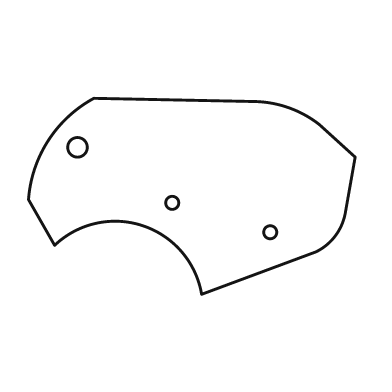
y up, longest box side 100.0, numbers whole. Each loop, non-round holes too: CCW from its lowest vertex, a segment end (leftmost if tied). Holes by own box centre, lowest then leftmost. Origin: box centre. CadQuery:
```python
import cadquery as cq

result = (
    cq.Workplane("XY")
    .moveTo(3.0, -30.0)
    .lineTo(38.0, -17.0)
    .threePointArc((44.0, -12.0), (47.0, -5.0))
    .lineTo(50.0, 12.0)
    .lineTo(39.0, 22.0)
    .threePointArc((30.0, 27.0), (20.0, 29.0))
    .lineTo(-30.0, 30.0)
    .threePointArc((-44.0, 17.0), (-50.0, -1.0))
    .lineTo(-42.0, -15.0)
    .threePointArc((-15.0, -9.0), (3.0, -30.0))
    .close()
    .moveTo(24.0, -11.0)
    .circle(2.0)
    .moveTo(-6.0, -2.0)
    .circle(2.0)
    .moveTo(-35.0, 15.0)
    .circle(3.0)
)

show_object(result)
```